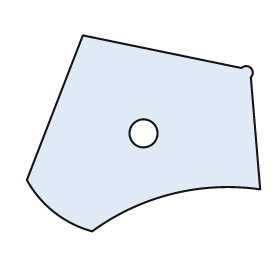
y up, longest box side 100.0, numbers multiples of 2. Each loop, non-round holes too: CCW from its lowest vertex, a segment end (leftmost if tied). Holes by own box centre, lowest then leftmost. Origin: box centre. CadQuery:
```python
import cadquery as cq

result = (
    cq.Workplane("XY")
    .moveTo(-22.0, -42.0)
    .threePointArc((12.0, -26.0), (50.0, -24.0))
    .lineTo(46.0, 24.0)
    .threePointArc((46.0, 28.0), (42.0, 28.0))
    .lineTo(-26.0, 42.0)
    .lineTo(-50.0, -20.0)
    .threePointArc((-38.0, -34.0), (-22.0, -42.0))
    .close()
    .moveTo(0.0, 0.0)
    .circle(6.0)
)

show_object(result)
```